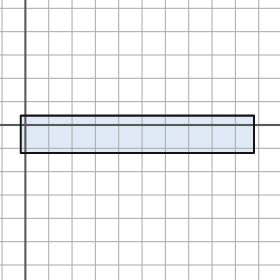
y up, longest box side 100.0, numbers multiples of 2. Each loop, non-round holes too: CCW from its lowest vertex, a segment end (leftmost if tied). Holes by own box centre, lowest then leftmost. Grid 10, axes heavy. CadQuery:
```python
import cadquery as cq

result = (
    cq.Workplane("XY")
    .moveTo(-2.0, -12.0)
    .lineTo(98.0, -12.0)
    .lineTo(98.0, 4.0)
    .lineTo(-2.0, 4.0)
    .close()
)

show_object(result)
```